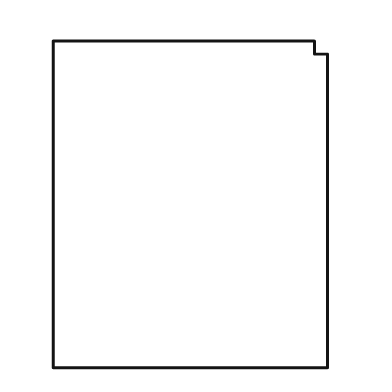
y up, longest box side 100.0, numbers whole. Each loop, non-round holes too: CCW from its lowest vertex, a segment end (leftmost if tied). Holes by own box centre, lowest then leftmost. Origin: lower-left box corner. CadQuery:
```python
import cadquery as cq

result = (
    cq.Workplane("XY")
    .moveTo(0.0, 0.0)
    .lineTo(84.0, 0.0)
    .lineTo(84.0, 96.0)
    .lineTo(80.0, 96.0)
    .lineTo(80.0, 100.0)
    .lineTo(0.0, 100.0)
    .close()
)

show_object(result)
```